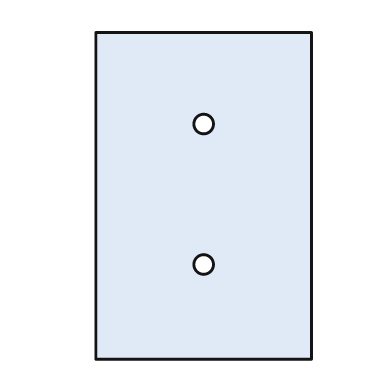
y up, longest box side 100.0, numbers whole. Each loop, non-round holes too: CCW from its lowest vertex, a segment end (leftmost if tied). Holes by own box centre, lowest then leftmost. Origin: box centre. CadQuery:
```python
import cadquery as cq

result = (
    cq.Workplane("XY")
    .moveTo(-33.0, -50.0)
    .lineTo(33.0, -50.0)
    .lineTo(33.0, 50.0)
    .lineTo(-33.0, 50.0)
    .close()
    .moveTo(0.0, -21.0)
    .circle(3.0)
    .moveTo(0.0, 22.0)
    .circle(3.0)
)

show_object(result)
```